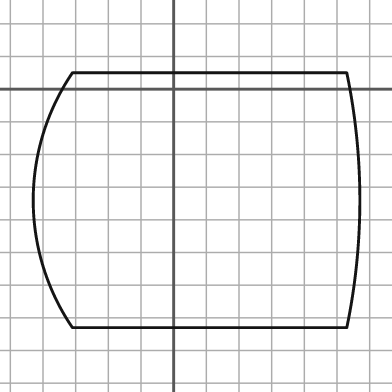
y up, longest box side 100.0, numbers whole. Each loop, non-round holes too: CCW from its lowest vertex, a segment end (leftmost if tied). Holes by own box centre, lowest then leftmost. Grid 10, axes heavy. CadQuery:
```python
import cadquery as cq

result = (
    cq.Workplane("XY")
    .moveTo(-31.0, -73.0)
    .lineTo(53.0, -73.0)
    .threePointArc((57.0, -34.0), (53.0, 5.0))
    .lineTo(-31.0, 5.0)
    .threePointArc((-43.0, -34.0), (-31.0, -73.0))
    .close()
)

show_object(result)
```